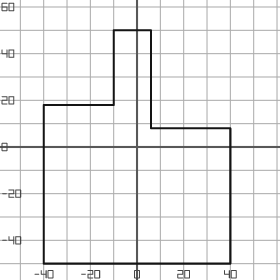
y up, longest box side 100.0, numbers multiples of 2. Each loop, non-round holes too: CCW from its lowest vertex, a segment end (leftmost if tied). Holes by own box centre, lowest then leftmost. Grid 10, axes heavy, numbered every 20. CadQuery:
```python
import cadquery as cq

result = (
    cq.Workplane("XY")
    .moveTo(-40.0, -50.0)
    .lineTo(40.0, -50.0)
    .lineTo(40.0, 8.0)
    .lineTo(6.0, 8.0)
    .lineTo(6.0, 50.0)
    .lineTo(-10.0, 50.0)
    .lineTo(-10.0, 18.0)
    .lineTo(-40.0, 18.0)
    .close()
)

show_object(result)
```